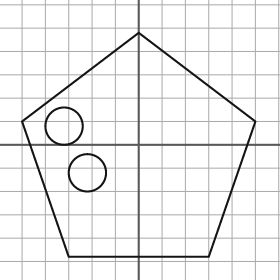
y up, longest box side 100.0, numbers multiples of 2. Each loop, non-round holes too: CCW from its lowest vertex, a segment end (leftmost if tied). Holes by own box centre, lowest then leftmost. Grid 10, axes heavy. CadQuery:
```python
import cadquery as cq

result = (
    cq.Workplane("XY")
    .moveTo(-30.0, -48.0)
    .lineTo(30.0, -48.0)
    .lineTo(50.0, 10.0)
    .lineTo(0.0, 48.0)
    .lineTo(-50.0, 10.0)
    .close()
    .moveTo(-22.0, -12.0)
    .circle(8.0)
    .moveTo(-32.0, 8.0)
    .circle(8.0)
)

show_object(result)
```